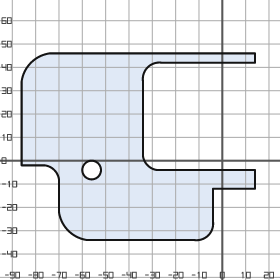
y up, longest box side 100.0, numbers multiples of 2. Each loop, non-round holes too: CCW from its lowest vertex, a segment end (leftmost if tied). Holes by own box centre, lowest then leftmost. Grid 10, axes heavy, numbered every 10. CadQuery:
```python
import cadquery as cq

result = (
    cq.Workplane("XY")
    .moveTo(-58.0, -34.0)
    .lineTo(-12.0, -34.0)
    .threePointArc((-6.0, -32.0), (-4.0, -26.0))
    .lineTo(-4.0, -12.0)
    .lineTo(14.0, -12.0)
    .lineTo(14.0, -4.0)
    .lineTo(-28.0, -4.0)
    .threePointArc((-32.0, -2.0), (-34.0, 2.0))
    .lineTo(-34.0, 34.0)
    .threePointArc((-32.0, 40.0), (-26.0, 42.0))
    .lineTo(14.0, 42.0)
    .lineTo(14.0, 46.0)
    .lineTo(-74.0, 46.0)
    .threePointArc((-82.0, 42.0), (-86.0, 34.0))
    .lineTo(-86.0, -2.0)
    .lineTo(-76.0, -2.0)
    .threePointArc((-72.0, -4.0), (-70.0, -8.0))
    .lineTo(-70.0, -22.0)
    .threePointArc((-66.0, -30.0), (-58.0, -34.0))
    .close()
    .moveTo(-56.0, -4.0)
    .circle(4.0)
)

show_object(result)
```